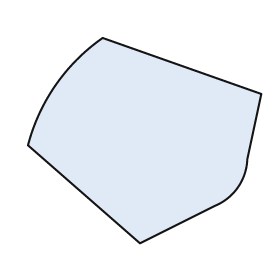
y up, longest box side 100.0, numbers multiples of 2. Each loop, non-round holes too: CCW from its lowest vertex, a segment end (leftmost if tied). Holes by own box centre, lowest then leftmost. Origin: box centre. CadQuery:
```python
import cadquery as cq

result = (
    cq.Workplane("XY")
    .moveTo(-2.0, -44.0)
    .lineTo(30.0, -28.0)
    .threePointArc((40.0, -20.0), (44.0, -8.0))
    .lineTo(50.0, 20.0)
    .lineTo(-18.0, 44.0)
    .threePointArc((-38.0, 24.0), (-50.0, -2.0))
    .close()
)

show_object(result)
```